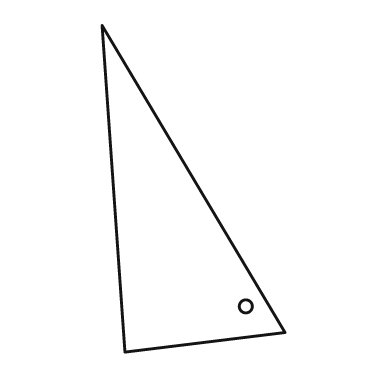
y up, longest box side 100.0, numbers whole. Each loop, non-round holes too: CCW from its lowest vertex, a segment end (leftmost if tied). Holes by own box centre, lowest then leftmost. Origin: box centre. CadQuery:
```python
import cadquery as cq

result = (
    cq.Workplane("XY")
    .moveTo(-21.0, -50.0)
    .lineTo(28.0, -44.0)
    .lineTo(-28.0, 50.0)
    .close()
    .moveTo(16.0, -36.0)
    .circle(2.0)
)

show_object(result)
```